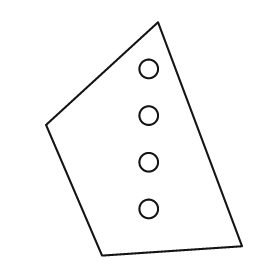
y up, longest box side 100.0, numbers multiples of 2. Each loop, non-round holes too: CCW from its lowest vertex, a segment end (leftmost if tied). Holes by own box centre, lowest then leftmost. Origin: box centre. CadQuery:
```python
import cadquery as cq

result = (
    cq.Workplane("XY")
    .moveTo(-18.0, -50.0)
    .lineTo(42.0, -46.0)
    .lineTo(6.0, 50.0)
    .lineTo(-42.0, 6.0)
    .close()
    .moveTo(2.0, -30.0)
    .circle(4.0)
    .moveTo(2.0, -10.0)
    .circle(4.0)
    .moveTo(2.0, 10.0)
    .circle(4.0)
    .moveTo(2.0, 30.0)
    .circle(4.0)
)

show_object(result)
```